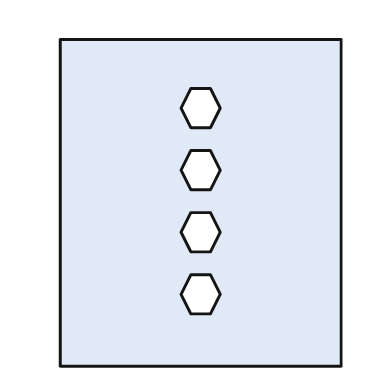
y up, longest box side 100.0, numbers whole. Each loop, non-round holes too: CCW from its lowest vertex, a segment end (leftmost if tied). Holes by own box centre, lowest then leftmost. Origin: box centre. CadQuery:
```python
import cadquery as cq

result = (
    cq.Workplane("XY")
    .moveTo(-43.0, -50.0)
    .lineTo(43.0, -50.0)
    .lineTo(43.0, 50.0)
    .lineTo(-43.0, 50.0)
    .close()
    .moveTo(-3.0, -34.0)
    .lineTo(3.0, -34.0)
    .lineTo(6.0, -28.0)
    .lineTo(3.0, -22.0)
    .lineTo(-3.0, -22.0)
    .lineTo(-6.0, -28.0)
    .close()
    .moveTo(-3.0, -15.0)
    .lineTo(3.0, -15.0)
    .lineTo(6.0, -9.0)
    .lineTo(3.0, -3.0)
    .lineTo(-3.0, -3.0)
    .lineTo(-6.0, -9.0)
    .close()
    .moveTo(-3.0, 4.0)
    .lineTo(3.0, 4.0)
    .lineTo(6.0, 10.0)
    .lineTo(3.0, 16.0)
    .lineTo(-3.0, 16.0)
    .lineTo(-6.0, 10.0)
    .close()
    .moveTo(-3.0, 23.0)
    .lineTo(3.0, 23.0)
    .lineTo(6.0, 29.0)
    .lineTo(3.0, 35.0)
    .lineTo(-3.0, 35.0)
    .lineTo(-6.0, 29.0)
    .close()
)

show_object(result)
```